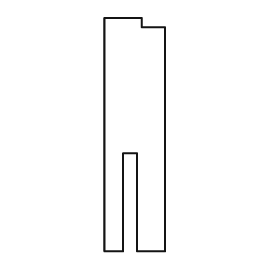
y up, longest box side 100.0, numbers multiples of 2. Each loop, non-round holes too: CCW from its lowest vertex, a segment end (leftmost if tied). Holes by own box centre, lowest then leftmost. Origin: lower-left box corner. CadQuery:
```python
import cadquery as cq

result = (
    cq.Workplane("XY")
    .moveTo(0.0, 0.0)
    .lineTo(8.0, 0.0)
    .lineTo(8.0, 42.0)
    .lineTo(14.0, 42.0)
    .lineTo(14.0, 0.0)
    .lineTo(26.0, 0.0)
    .lineTo(26.0, 96.0)
    .lineTo(16.0, 96.0)
    .lineTo(16.0, 100.0)
    .lineTo(0.0, 100.0)
    .close()
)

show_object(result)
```